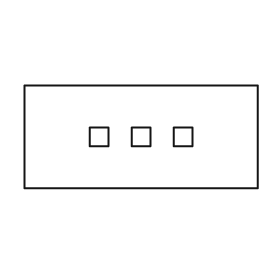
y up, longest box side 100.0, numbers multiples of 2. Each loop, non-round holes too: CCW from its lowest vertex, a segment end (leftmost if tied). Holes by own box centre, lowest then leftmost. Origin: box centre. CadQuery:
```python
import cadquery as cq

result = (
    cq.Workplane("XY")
    .moveTo(-50.0, -22.0)
    .lineTo(50.0, -22.0)
    .lineTo(50.0, 22.0)
    .lineTo(-50.0, 22.0)
    .close()
    .moveTo(-22.0, -4.0)
    .lineTo(-14.0, -4.0)
    .lineTo(-14.0, 4.0)
    .lineTo(-22.0, 4.0)
    .close()
    .moveTo(-4.0, -4.0)
    .lineTo(4.0, -4.0)
    .lineTo(4.0, 4.0)
    .lineTo(-4.0, 4.0)
    .close()
    .moveTo(14.0, -4.0)
    .lineTo(22.0, -4.0)
    .lineTo(22.0, 4.0)
    .lineTo(14.0, 4.0)
    .close()
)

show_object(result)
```